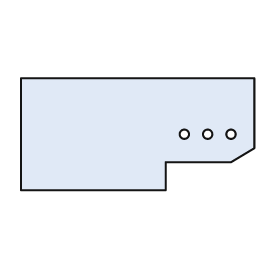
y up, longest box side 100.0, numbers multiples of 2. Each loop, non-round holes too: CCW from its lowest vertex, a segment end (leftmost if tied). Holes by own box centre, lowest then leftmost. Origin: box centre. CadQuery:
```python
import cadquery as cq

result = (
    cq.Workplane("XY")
    .moveTo(-50.0, -24.0)
    .lineTo(12.0, -24.0)
    .lineTo(12.0, -12.0)
    .lineTo(40.0, -12.0)
    .lineTo(50.0, -6.0)
    .lineTo(50.0, 24.0)
    .lineTo(-50.0, 24.0)
    .close()
    .moveTo(20.0, 0.0)
    .circle(2.0)
    .moveTo(30.0, 0.0)
    .circle(2.0)
    .moveTo(40.0, 0.0)
    .circle(2.0)
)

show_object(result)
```